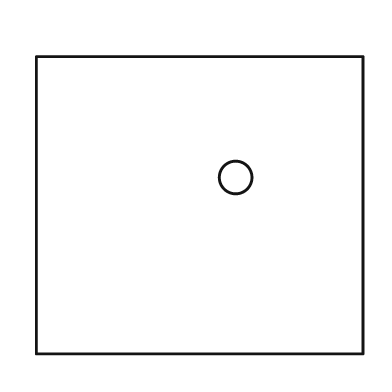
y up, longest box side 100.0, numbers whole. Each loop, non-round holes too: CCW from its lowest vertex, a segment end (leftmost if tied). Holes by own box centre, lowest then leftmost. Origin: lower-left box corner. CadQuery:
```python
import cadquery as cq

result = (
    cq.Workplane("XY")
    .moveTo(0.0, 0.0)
    .lineTo(100.0, 0.0)
    .lineTo(100.0, 91.0)
    .lineTo(0.0, 91.0)
    .close()
    .moveTo(61.0, 54.0)
    .circle(5.0)
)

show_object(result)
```